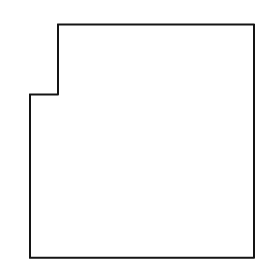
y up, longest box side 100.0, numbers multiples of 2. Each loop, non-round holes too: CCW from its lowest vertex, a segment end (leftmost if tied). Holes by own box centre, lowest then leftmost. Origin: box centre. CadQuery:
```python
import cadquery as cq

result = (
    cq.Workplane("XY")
    .moveTo(-48.0, -50.0)
    .lineTo(48.0, -50.0)
    .lineTo(48.0, 50.0)
    .lineTo(-36.0, 50.0)
    .lineTo(-36.0, 20.0)
    .lineTo(-48.0, 20.0)
    .close()
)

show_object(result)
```